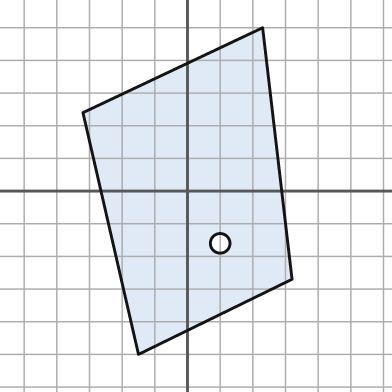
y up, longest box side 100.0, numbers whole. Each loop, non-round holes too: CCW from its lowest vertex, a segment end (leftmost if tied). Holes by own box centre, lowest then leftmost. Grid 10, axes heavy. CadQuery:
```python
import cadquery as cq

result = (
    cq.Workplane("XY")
    .moveTo(-15.0, -50.0)
    .lineTo(32.0, -27.0)
    .lineTo(23.0, 50.0)
    .lineTo(-32.0, 24.0)
    .close()
    .moveTo(10.0, -16.0)
    .circle(3.0)
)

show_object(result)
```